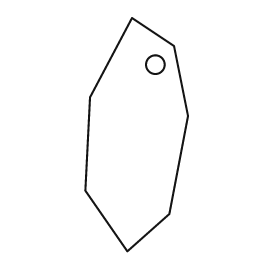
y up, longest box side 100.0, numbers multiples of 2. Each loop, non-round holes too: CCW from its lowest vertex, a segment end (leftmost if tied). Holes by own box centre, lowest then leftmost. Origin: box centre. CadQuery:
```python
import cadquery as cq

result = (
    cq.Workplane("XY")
    .moveTo(-4.0, -50.0)
    .lineTo(14.0, -34.0)
    .lineTo(22.0, 8.0)
    .lineTo(16.0, 38.0)
    .lineTo(-2.0, 50.0)
    .lineTo(-20.0, 16.0)
    .lineTo(-22.0, -24.0)
    .close()
    .moveTo(8.0, 30.0)
    .circle(4.0)
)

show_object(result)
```